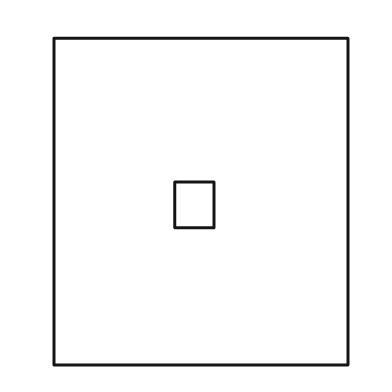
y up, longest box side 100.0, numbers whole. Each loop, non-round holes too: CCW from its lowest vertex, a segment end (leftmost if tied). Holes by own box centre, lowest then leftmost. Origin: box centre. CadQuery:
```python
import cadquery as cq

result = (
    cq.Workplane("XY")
    .moveTo(-45.0, -50.0)
    .lineTo(45.0, -50.0)
    .lineTo(45.0, 50.0)
    .lineTo(-45.0, 50.0)
    .close()
    .moveTo(-8.0, -8.0)
    .lineTo(4.0, -8.0)
    .lineTo(4.0, 6.0)
    .lineTo(-8.0, 6.0)
    .close()
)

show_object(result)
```